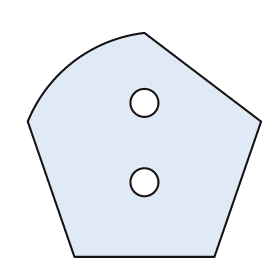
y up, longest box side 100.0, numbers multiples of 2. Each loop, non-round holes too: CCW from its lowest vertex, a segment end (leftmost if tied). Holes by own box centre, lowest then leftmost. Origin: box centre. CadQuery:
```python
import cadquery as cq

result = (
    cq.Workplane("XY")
    .moveTo(-30.0, -48.0)
    .lineTo(30.0, -48.0)
    .lineTo(50.0, 10.0)
    .lineTo(0.0, 48.0)
    .threePointArc((-30.0, 36.0), (-50.0, 10.0))
    .close()
    .moveTo(0.0, -16.0)
    .circle(6.0)
    .moveTo(0.0, 18.0)
    .circle(6.0)
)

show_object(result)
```